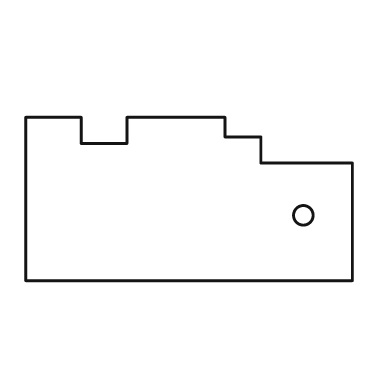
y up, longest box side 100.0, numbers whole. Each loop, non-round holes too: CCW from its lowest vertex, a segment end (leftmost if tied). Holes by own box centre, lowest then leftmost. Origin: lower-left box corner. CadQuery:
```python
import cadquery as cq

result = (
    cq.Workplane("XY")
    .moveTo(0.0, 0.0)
    .lineTo(100.0, 0.0)
    .lineTo(100.0, 36.0)
    .lineTo(72.0, 36.0)
    .lineTo(72.0, 44.0)
    .lineTo(61.0, 44.0)
    .lineTo(61.0, 50.0)
    .lineTo(31.0, 50.0)
    .lineTo(31.0, 42.0)
    .lineTo(17.0, 42.0)
    .lineTo(17.0, 50.0)
    .lineTo(0.0, 50.0)
    .close()
    .moveTo(85.0, 20.0)
    .circle(3.0)
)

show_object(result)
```